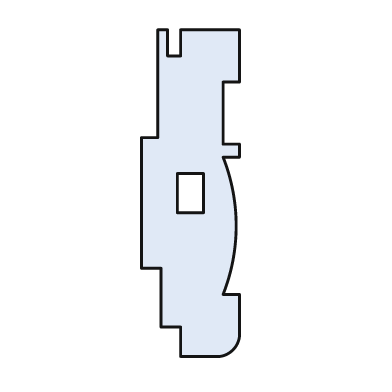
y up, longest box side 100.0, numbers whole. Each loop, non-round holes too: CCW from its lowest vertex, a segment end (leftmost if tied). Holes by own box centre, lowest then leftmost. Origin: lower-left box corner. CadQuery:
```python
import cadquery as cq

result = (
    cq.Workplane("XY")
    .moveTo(12.0, 0.0)
    .lineTo(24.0, 0.0)
    .threePointArc((28.0, 2.0), (30.0, 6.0))
    .lineTo(30.0, 19.0)
    .lineTo(25.0, 19.0)
    .threePointArc((29.0, 40.0), (25.0, 61.0))
    .lineTo(30.0, 61.0)
    .lineTo(30.0, 65.0)
    .lineTo(25.0, 65.0)
    .lineTo(25.0, 84.0)
    .lineTo(30.0, 84.0)
    .lineTo(30.0, 100.0)
    .lineTo(12.0, 100.0)
    .lineTo(12.0, 92.0)
    .lineTo(8.0, 92.0)
    .lineTo(8.0, 100.0)
    .lineTo(5.0, 100.0)
    .lineTo(5.0, 67.0)
    .lineTo(0.0, 67.0)
    .lineTo(0.0, 27.0)
    .lineTo(6.0, 27.0)
    .lineTo(6.0, 9.0)
    .lineTo(12.0, 9.0)
    .close()
    .moveTo(11.0, 44.0)
    .lineTo(19.0, 44.0)
    .lineTo(19.0, 56.0)
    .lineTo(11.0, 56.0)
    .close()
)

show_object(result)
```